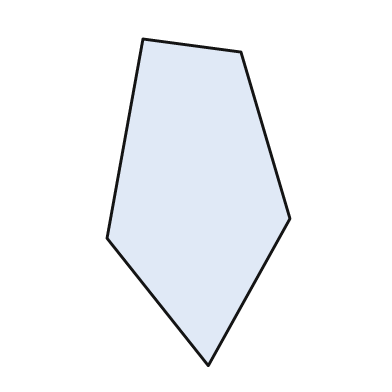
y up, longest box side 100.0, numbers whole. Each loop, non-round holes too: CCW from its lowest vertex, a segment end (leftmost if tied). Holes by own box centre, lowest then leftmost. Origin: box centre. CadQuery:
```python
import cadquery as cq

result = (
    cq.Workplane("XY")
    .moveTo(3.0, -50.0)
    .lineTo(28.0, -5.0)
    .lineTo(13.0, 46.0)
    .lineTo(-17.0, 50.0)
    .lineTo(-28.0, -11.0)
    .close()
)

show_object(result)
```